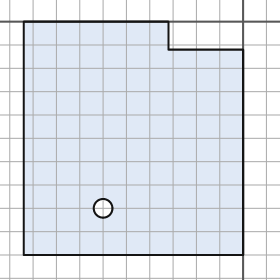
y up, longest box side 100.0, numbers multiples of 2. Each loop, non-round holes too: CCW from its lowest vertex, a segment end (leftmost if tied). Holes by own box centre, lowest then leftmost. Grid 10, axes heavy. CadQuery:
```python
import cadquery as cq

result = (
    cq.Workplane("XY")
    .moveTo(-94.0, -100.0)
    .lineTo(0.0, -100.0)
    .lineTo(0.0, -12.0)
    .lineTo(-32.0, -12.0)
    .lineTo(-32.0, 0.0)
    .lineTo(-94.0, 0.0)
    .close()
    .moveTo(-60.0, -80.0)
    .circle(4.0)
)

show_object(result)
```